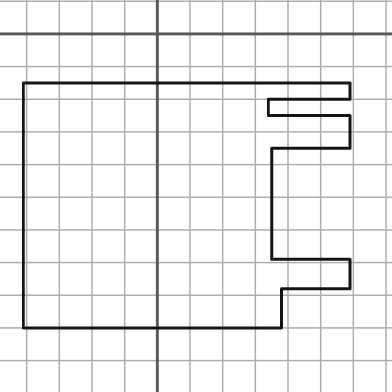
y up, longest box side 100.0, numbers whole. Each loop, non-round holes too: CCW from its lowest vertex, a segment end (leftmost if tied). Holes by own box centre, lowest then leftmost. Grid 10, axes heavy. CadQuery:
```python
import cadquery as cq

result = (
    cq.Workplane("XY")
    .moveTo(-41.0, -90.0)
    .lineTo(38.0, -90.0)
    .lineTo(38.0, -78.0)
    .lineTo(59.0, -78.0)
    .lineTo(59.0, -69.0)
    .lineTo(35.0, -69.0)
    .lineTo(35.0, -35.0)
    .lineTo(59.0, -35.0)
    .lineTo(59.0, -25.0)
    .lineTo(34.0, -25.0)
    .lineTo(34.0, -20.0)
    .lineTo(59.0, -20.0)
    .lineTo(59.0, -15.0)
    .lineTo(-41.0, -15.0)
    .close()
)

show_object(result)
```